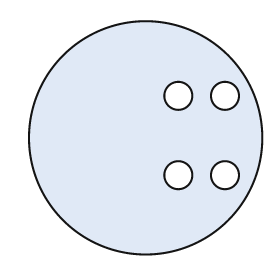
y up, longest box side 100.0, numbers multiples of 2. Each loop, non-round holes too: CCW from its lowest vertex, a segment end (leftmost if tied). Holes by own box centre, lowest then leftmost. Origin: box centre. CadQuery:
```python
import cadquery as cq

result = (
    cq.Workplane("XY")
    .moveTo(0.0, 0.0)
    .circle(50.0)
    .moveTo(14.0, -16.0)
    .circle(6.0)
    .moveTo(34.0, -16.0)
    .circle(6.0)
    .moveTo(14.0, 18.0)
    .circle(6.0)
    .moveTo(34.0, 18.0)
    .circle(6.0)
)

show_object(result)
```